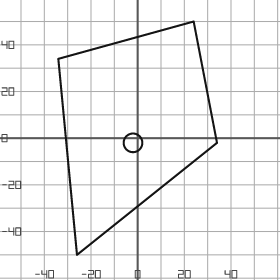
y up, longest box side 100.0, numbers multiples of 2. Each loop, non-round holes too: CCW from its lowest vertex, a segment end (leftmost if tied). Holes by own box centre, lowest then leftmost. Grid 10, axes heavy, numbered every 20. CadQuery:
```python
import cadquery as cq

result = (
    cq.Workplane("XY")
    .moveTo(-26.0, -50.0)
    .lineTo(34.0, -2.0)
    .lineTo(24.0, 50.0)
    .lineTo(-34.0, 34.0)
    .close()
    .moveTo(-2.0, -2.0)
    .circle(4.0)
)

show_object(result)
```